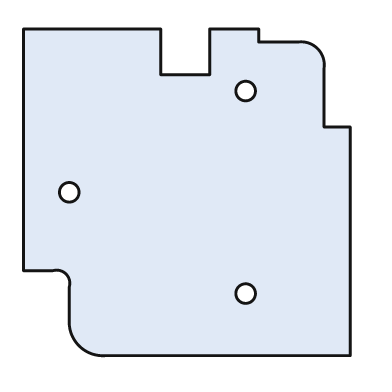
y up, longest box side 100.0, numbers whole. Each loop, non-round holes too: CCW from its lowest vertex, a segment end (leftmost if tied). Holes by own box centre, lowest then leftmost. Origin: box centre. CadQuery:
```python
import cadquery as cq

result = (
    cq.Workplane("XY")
    .moveTo(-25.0, -50.0)
    .lineTo(50.0, -50.0)
    .lineTo(50.0, 20.0)
    .lineTo(42.0, 20.0)
    .lineTo(42.0, 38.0)
    .threePointArc((40.0, 44.0), (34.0, 46.0))
    .lineTo(22.0, 46.0)
    .lineTo(22.0, 50.0)
    .lineTo(7.0, 50.0)
    .lineTo(7.0, 36.0)
    .lineTo(-8.0, 36.0)
    .lineTo(-8.0, 50.0)
    .lineTo(-50.0, 50.0)
    .lineTo(-50.0, -24.0)
    .lineTo(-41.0, -24.0)
    .threePointArc((-37.0, -25.0), (-36.0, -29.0))
    .lineTo(-36.0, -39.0)
    .threePointArc((-33.0, -47.0), (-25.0, -50.0))
    .close()
    .moveTo(18.0, -31.0)
    .circle(3.0)
    .moveTo(-36.0, 0.0)
    .circle(3.0)
    .moveTo(18.0, 31.0)
    .circle(3.0)
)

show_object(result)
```